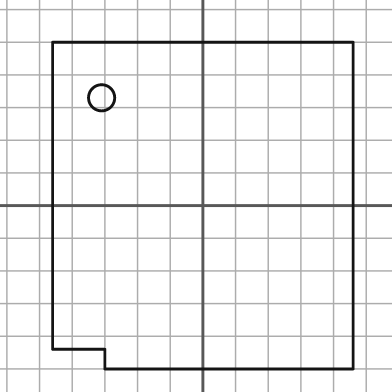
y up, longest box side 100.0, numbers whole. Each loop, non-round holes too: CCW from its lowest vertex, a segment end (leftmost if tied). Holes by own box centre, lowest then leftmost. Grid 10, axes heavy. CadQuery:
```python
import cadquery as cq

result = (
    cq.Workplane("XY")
    .moveTo(-30.0, -50.0)
    .lineTo(46.0, -50.0)
    .lineTo(46.0, 50.0)
    .lineTo(-46.0, 50.0)
    .lineTo(-46.0, -44.0)
    .lineTo(-30.0, -44.0)
    .close()
    .moveTo(-31.0, 33.0)
    .circle(4.0)
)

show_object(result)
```